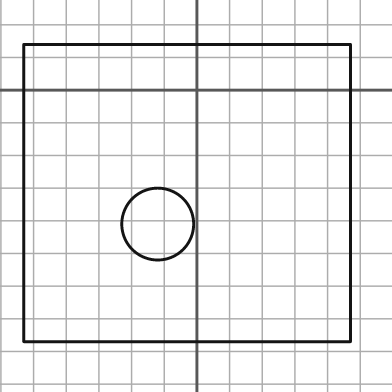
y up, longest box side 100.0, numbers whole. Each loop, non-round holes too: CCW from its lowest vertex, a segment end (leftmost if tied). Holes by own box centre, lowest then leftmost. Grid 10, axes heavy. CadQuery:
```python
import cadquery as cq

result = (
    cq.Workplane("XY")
    .moveTo(-53.0, -77.0)
    .lineTo(47.0, -77.0)
    .lineTo(47.0, 14.0)
    .lineTo(-53.0, 14.0)
    .close()
    .moveTo(-12.0, -41.0)
    .circle(11.0)
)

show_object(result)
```